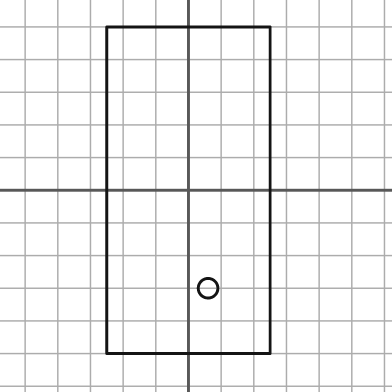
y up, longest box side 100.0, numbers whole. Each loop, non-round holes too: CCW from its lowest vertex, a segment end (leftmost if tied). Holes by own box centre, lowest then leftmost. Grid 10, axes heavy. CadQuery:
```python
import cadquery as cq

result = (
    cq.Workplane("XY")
    .moveTo(-25.0, -50.0)
    .lineTo(25.0, -50.0)
    .lineTo(25.0, 50.0)
    .lineTo(-25.0, 50.0)
    .close()
    .moveTo(6.0, -30.0)
    .circle(3.0)
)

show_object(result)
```